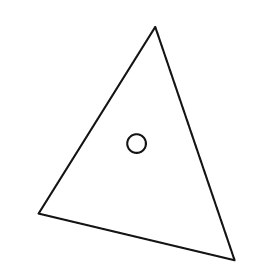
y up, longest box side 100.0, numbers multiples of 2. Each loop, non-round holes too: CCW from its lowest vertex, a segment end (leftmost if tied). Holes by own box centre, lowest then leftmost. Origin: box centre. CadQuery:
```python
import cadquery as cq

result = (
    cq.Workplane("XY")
    .moveTo(42.0, -50.0)
    .lineTo(8.0, 50.0)
    .lineTo(-42.0, -30.0)
    .close()
    .moveTo(0.0, 0.0)
    .circle(4.0)
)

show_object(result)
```